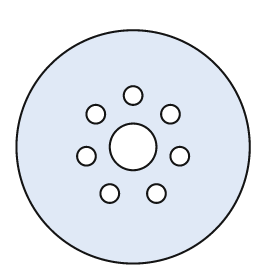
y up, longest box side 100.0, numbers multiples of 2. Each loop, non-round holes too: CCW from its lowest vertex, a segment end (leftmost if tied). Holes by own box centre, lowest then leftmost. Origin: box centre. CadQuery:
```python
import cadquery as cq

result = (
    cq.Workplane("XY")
    .moveTo(0.0, 0.0)
    .circle(50.0)
    .moveTo(-10.0, -20.0)
    .circle(4.0)
    .moveTo(10.0, -20.0)
    .circle(4.0)
    .moveTo(-20.0, -4.0)
    .circle(4.0)
    .moveTo(20.0, -4.0)
    .circle(4.0)
    .moveTo(0.0, 0.0)
    .circle(10.0)
    .moveTo(-16.0, 14.0)
    .circle(4.0)
    .moveTo(16.0, 14.0)
    .circle(4.0)
    .moveTo(0.0, 22.0)
    .circle(4.0)
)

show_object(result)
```